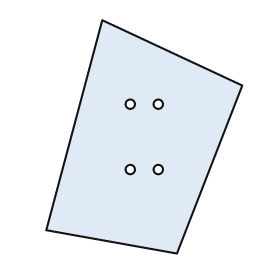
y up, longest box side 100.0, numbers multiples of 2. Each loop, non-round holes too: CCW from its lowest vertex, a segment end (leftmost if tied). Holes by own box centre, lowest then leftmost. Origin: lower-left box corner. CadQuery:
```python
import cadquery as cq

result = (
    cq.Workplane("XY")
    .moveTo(56.0, 0.0)
    .lineTo(84.0, 72.0)
    .lineTo(24.0, 100.0)
    .lineTo(0.0, 10.0)
    .close()
    .moveTo(36.0, 36.0)
    .circle(2.0)
    .moveTo(48.0, 36.0)
    .circle(2.0)
    .moveTo(36.0, 64.0)
    .circle(2.0)
    .moveTo(48.0, 64.0)
    .circle(2.0)
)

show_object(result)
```